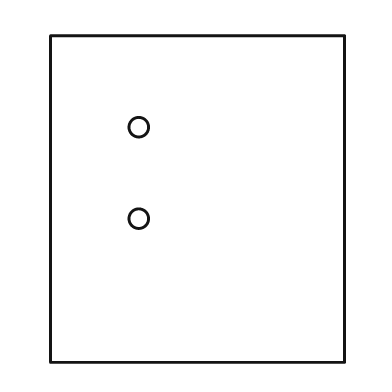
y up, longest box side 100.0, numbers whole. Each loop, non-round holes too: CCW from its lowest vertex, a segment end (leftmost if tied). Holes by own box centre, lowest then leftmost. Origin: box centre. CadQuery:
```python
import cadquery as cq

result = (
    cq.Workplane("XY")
    .moveTo(-45.0, -50.0)
    .lineTo(45.0, -50.0)
    .lineTo(45.0, 50.0)
    .lineTo(-45.0, 50.0)
    .close()
    .moveTo(-18.0, -6.0)
    .circle(3.0)
    .moveTo(-18.0, 22.0)
    .circle(3.0)
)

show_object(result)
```